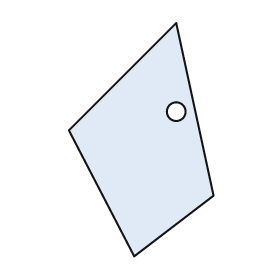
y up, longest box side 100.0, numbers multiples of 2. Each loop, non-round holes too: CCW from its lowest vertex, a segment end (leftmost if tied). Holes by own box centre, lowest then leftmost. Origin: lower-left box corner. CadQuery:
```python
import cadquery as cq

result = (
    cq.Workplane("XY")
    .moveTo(28.0, 0.0)
    .lineTo(62.0, 26.0)
    .lineTo(46.0, 100.0)
    .lineTo(0.0, 54.0)
    .close()
    .moveTo(46.0, 62.0)
    .circle(4.0)
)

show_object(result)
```